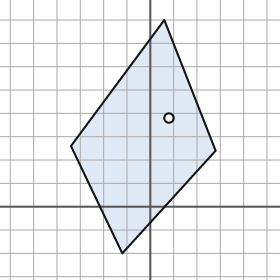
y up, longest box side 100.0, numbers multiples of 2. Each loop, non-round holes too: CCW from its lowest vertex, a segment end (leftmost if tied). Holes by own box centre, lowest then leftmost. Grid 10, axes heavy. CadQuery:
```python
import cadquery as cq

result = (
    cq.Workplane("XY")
    .moveTo(-12.0, -20.0)
    .lineTo(28.0, 24.0)
    .lineTo(6.0, 80.0)
    .lineTo(-34.0, 26.0)
    .close()
    .moveTo(8.0, 38.0)
    .circle(2.0)
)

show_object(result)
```